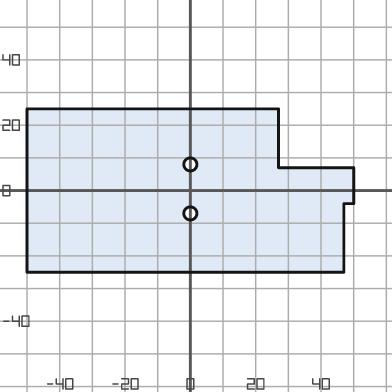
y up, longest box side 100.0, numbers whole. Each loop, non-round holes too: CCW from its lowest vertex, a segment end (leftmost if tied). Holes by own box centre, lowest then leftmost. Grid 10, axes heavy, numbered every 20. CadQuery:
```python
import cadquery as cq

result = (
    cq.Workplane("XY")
    .moveTo(-50.0, -25.0)
    .lineTo(47.0, -25.0)
    .lineTo(47.0, -4.0)
    .lineTo(50.0, -4.0)
    .lineTo(50.0, 7.0)
    .lineTo(27.0, 7.0)
    .lineTo(27.0, 25.0)
    .lineTo(-50.0, 25.0)
    .close()
    .moveTo(0.0, -7.0)
    .circle(2.0)
    .moveTo(0.0, 8.0)
    .circle(2.0)
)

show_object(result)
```